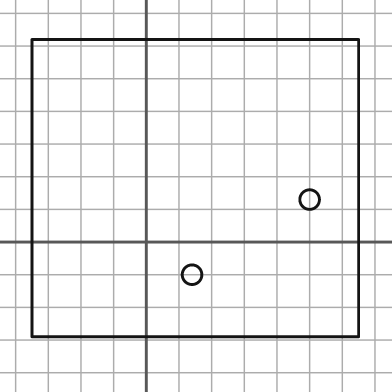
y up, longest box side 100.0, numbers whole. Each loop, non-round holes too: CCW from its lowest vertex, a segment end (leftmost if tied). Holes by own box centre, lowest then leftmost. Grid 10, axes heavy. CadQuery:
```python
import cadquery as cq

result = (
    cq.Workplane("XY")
    .moveTo(-35.0, -29.0)
    .lineTo(65.0, -29.0)
    .lineTo(65.0, 62.0)
    .lineTo(-35.0, 62.0)
    .close()
    .moveTo(14.0, -10.0)
    .circle(3.0)
    .moveTo(50.0, 13.0)
    .circle(3.0)
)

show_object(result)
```